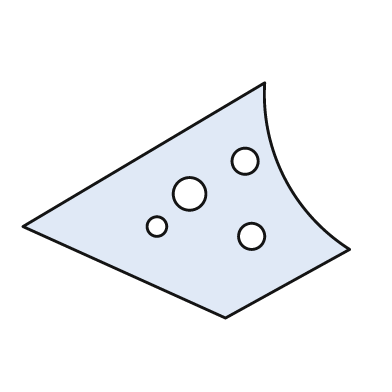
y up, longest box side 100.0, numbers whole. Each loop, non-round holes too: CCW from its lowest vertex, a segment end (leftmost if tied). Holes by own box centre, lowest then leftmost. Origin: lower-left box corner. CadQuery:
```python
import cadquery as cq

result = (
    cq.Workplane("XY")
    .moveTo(62.0, 0.0)
    .lineTo(100.0, 21.0)
    .threePointArc((80.0, 43.0), (74.0, 72.0))
    .lineTo(0.0, 28.0)
    .close()
    .moveTo(70.0, 25.0)
    .circle(4.0)
    .moveTo(41.0, 28.0)
    .circle(3.0)
    .moveTo(51.0, 38.0)
    .circle(5.0)
    .moveTo(68.0, 48.0)
    .circle(4.0)
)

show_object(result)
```